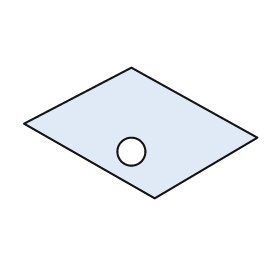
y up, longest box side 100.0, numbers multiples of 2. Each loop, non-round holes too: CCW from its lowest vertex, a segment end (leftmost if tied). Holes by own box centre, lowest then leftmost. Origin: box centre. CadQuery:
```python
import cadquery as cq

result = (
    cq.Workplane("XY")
    .moveTo(6.0, -28.0)
    .lineTo(50.0, -2.0)
    .lineTo(-4.0, 28.0)
    .lineTo(-50.0, 4.0)
    .close()
    .moveTo(-4.0, -8.0)
    .circle(6.0)
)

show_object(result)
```